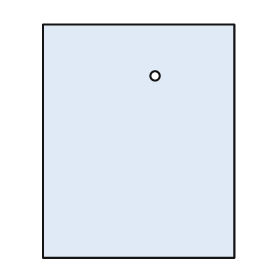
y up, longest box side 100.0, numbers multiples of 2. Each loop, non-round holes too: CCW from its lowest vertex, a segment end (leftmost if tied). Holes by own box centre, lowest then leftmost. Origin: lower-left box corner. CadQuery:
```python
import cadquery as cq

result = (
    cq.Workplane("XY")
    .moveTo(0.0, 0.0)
    .lineTo(82.0, 0.0)
    .lineTo(82.0, 100.0)
    .lineTo(0.0, 100.0)
    .close()
    .moveTo(48.0, 78.0)
    .circle(2.0)
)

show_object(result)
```